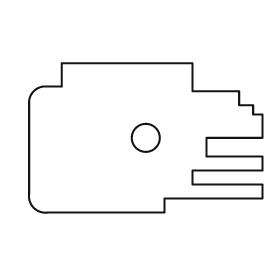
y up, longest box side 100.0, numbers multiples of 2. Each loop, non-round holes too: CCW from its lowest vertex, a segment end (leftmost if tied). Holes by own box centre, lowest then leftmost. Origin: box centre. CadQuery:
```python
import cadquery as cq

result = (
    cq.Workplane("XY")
    .moveTo(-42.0, -32.0)
    .lineTo(8.0, -32.0)
    .lineTo(8.0, -26.0)
    .lineTo(50.0, -26.0)
    .lineTo(50.0, -20.0)
    .lineTo(20.0, -20.0)
    .lineTo(20.0, -14.0)
    .lineTo(50.0, -14.0)
    .lineTo(50.0, -8.0)
    .lineTo(26.0, -8.0)
    .lineTo(26.0, 0.0)
    .lineTo(50.0, 0.0)
    .lineTo(50.0, 10.0)
    .lineTo(46.0, 10.0)
    .lineTo(46.0, 14.0)
    .lineTo(40.0, 14.0)
    .lineTo(40.0, 20.0)
    .lineTo(20.0, 20.0)
    .lineTo(20.0, 32.0)
    .lineTo(-36.0, 32.0)
    .lineTo(-36.0, 22.0)
    .lineTo(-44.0, 22.0)
    .threePointArc((-48.0, 20.0), (-50.0, 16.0))
    .lineTo(-50.0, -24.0)
    .threePointArc((-48.0, -30.0), (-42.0, -32.0))
    .close()
    .moveTo(0.0, 0.0)
    .circle(6.0)
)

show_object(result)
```